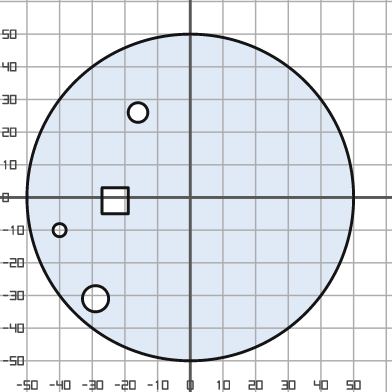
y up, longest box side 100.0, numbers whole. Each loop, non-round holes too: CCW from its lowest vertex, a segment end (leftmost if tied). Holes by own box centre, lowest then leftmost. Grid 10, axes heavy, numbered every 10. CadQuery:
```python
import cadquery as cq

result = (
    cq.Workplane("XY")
    .moveTo(0.0, 0.0)
    .circle(50.0)
    .moveTo(-29.0, -31.0)
    .circle(4.0)
    .moveTo(-40.0, -10.0)
    .circle(2.0)
    .moveTo(-27.0, -5.0)
    .lineTo(-19.0, -5.0)
    .lineTo(-19.0, 3.0)
    .lineTo(-27.0, 3.0)
    .close()
    .moveTo(-16.0, 26.0)
    .circle(3.0)
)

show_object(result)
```